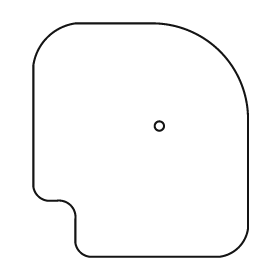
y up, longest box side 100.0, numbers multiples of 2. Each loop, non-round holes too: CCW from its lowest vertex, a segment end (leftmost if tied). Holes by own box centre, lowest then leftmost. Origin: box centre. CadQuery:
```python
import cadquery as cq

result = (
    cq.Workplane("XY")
    .moveTo(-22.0, -50.0)
    .lineTo(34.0, -50.0)
    .threePointArc((42.0, -46.0), (46.0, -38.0))
    .lineTo(46.0, 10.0)
    .threePointArc((34.0, 38.0), (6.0, 50.0))
    .lineTo(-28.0, 50.0)
    .threePointArc((-40.0, 44.0), (-46.0, 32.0))
    .lineTo(-46.0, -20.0)
    .threePointArc((-44.0, -24.0), (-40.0, -26.0))
    .lineTo(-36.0, -26.0)
    .threePointArc((-30.0, -28.0), (-28.0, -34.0))
    .lineTo(-28.0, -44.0)
    .threePointArc((-26.0, -48.0), (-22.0, -50.0))
    .close()
    .moveTo(8.0, 6.0)
    .circle(2.0)
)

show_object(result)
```